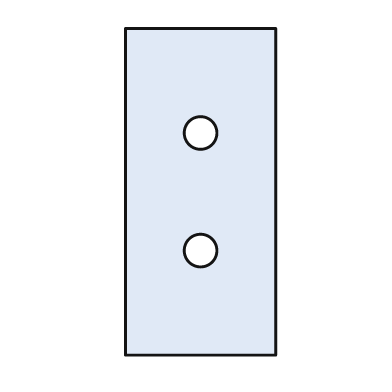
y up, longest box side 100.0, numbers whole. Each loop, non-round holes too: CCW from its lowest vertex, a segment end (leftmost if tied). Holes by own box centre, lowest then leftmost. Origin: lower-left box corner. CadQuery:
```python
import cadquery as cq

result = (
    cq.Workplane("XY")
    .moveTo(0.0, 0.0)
    .lineTo(46.0, 0.0)
    .lineTo(46.0, 100.0)
    .lineTo(0.0, 100.0)
    .close()
    .moveTo(23.0, 32.0)
    .circle(5.0)
    .moveTo(23.0, 68.0)
    .circle(5.0)
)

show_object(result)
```